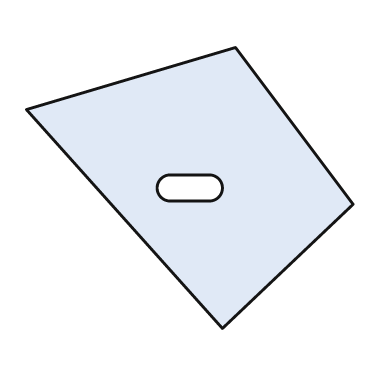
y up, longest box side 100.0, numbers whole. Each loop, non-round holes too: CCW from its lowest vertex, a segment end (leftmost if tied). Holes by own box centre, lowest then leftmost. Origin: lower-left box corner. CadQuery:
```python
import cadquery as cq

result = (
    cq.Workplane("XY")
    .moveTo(60.0, 0.0)
    .lineTo(100.0, 38.0)
    .lineTo(64.0, 86.0)
    .lineTo(0.0, 67.0)
    .close()
    .moveTo(44.0, 39.0)
    .lineTo(56.0, 39.0)
    .threePointArc((60.0, 43.0), (56.0, 47.0))
    .lineTo(44.0, 47.0)
    .threePointArc((40.0, 43.0), (44.0, 39.0))
    .close()
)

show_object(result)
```